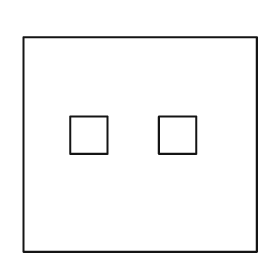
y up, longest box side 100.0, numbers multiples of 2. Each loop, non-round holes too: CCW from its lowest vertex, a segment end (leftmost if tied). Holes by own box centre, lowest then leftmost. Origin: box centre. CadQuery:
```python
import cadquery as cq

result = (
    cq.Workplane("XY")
    .moveTo(-50.0, -46.0)
    .lineTo(50.0, -46.0)
    .lineTo(50.0, 46.0)
    .lineTo(-50.0, 46.0)
    .close()
    .moveTo(-30.0, -4.0)
    .lineTo(-14.0, -4.0)
    .lineTo(-14.0, 12.0)
    .lineTo(-30.0, 12.0)
    .close()
    .moveTo(8.0, -4.0)
    .lineTo(24.0, -4.0)
    .lineTo(24.0, 12.0)
    .lineTo(8.0, 12.0)
    .close()
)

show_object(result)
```